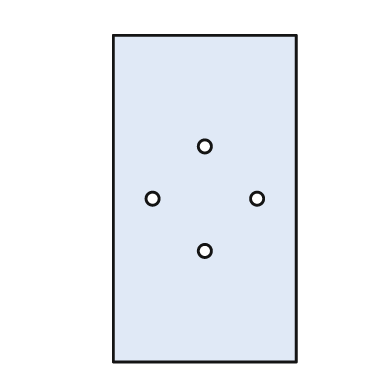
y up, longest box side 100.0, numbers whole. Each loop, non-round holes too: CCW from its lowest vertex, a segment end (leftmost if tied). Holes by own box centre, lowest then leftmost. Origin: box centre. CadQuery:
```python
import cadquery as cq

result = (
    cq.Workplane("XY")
    .moveTo(-28.0, -50.0)
    .lineTo(28.0, -50.0)
    .lineTo(28.0, 50.0)
    .lineTo(-28.0, 50.0)
    .close()
    .moveTo(0.0, -16.0)
    .circle(2.0)
    .moveTo(-16.0, 0.0)
    .circle(2.0)
    .moveTo(16.0, 0.0)
    .circle(2.0)
    .moveTo(0.0, 16.0)
    .circle(2.0)
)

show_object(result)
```